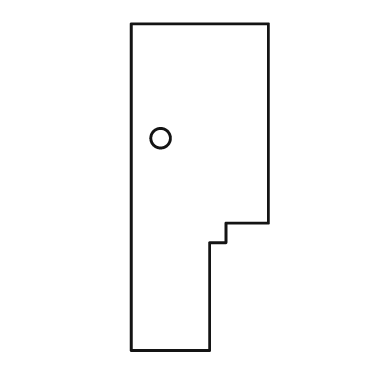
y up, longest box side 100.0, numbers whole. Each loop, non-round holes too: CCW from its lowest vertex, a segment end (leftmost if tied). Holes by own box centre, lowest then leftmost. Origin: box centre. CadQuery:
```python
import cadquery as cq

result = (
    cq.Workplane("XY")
    .moveTo(-21.0, -50.0)
    .lineTo(3.0, -50.0)
    .lineTo(3.0, -17.0)
    .lineTo(8.0, -17.0)
    .lineTo(8.0, -11.0)
    .lineTo(21.0, -11.0)
    .lineTo(21.0, 50.0)
    .lineTo(-21.0, 50.0)
    .close()
    .moveTo(-12.0, 15.0)
    .circle(3.0)
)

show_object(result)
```